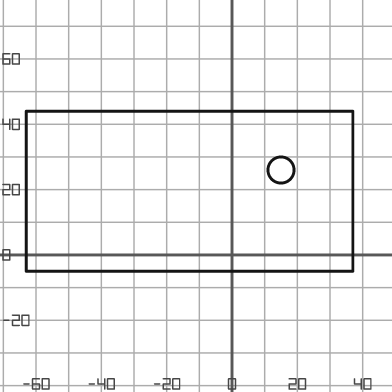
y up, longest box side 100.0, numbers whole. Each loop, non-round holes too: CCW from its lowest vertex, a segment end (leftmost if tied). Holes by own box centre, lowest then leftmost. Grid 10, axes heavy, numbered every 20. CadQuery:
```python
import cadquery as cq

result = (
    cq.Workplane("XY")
    .moveTo(-63.0, -5.0)
    .lineTo(37.0, -5.0)
    .lineTo(37.0, 44.0)
    .lineTo(-63.0, 44.0)
    .close()
    .moveTo(15.0, 26.0)
    .circle(4.0)
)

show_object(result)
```